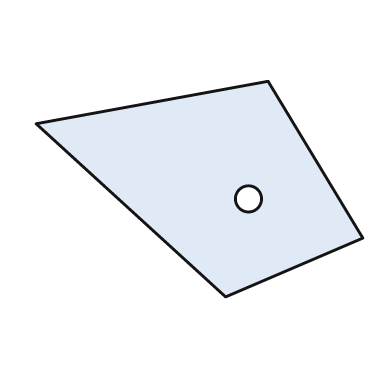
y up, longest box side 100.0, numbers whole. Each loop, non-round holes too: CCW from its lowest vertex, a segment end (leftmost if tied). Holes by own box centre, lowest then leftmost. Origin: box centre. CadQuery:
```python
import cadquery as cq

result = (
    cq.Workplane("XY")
    .moveTo(8.0, -33.0)
    .lineTo(50.0, -15.0)
    .lineTo(21.0, 33.0)
    .lineTo(-50.0, 20.0)
    .close()
    .moveTo(15.0, -3.0)
    .circle(4.0)
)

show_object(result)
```